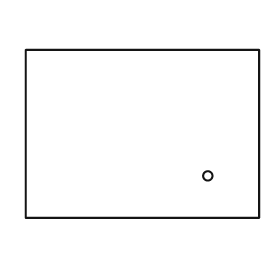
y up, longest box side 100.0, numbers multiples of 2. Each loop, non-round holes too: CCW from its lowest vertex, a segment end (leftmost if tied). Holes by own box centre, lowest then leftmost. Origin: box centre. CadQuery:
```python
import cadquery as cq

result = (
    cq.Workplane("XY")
    .moveTo(-50.0, -36.0)
    .lineTo(50.0, -36.0)
    .lineTo(50.0, 36.0)
    .lineTo(-50.0, 36.0)
    .close()
    .moveTo(28.0, -18.0)
    .circle(2.0)
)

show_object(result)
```